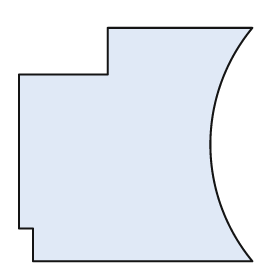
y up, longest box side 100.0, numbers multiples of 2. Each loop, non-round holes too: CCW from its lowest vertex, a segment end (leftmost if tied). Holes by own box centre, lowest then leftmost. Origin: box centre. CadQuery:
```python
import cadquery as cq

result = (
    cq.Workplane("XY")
    .moveTo(-44.0, -50.0)
    .lineTo(50.0, -50.0)
    .threePointArc((32.0, 0.0), (50.0, 50.0))
    .lineTo(-12.0, 50.0)
    .lineTo(-12.0, 30.0)
    .lineTo(-50.0, 30.0)
    .lineTo(-50.0, -36.0)
    .lineTo(-44.0, -36.0)
    .close()
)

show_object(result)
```